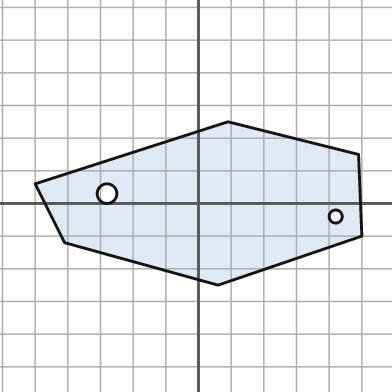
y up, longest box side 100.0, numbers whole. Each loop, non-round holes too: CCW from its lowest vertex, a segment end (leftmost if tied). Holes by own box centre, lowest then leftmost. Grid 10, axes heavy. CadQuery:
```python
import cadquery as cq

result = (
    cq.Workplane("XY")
    .moveTo(6.0, -25.0)
    .lineTo(50.0, -10.0)
    .lineTo(49.0, 15.0)
    .lineTo(9.0, 25.0)
    .lineTo(-50.0, 6.0)
    .lineTo(-41.0, -12.0)
    .close()
    .moveTo(42.0, -4.0)
    .circle(2.0)
    .moveTo(-28.0, 3.0)
    .circle(3.0)
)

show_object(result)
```